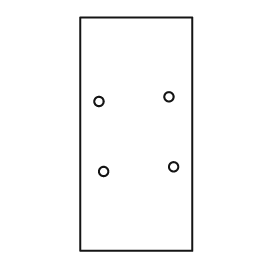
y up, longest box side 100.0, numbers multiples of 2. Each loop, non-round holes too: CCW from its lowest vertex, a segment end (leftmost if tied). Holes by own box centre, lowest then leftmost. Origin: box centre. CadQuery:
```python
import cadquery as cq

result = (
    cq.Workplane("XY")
    .moveTo(-24.0, -50.0)
    .lineTo(24.0, -50.0)
    .lineTo(24.0, 50.0)
    .lineTo(-24.0, 50.0)
    .close()
    .moveTo(-14.0, -16.0)
    .circle(2.0)
    .moveTo(16.0, -14.0)
    .circle(2.0)
    .moveTo(-16.0, 14.0)
    .circle(2.0)
    .moveTo(14.0, 16.0)
    .circle(2.0)
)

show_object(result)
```